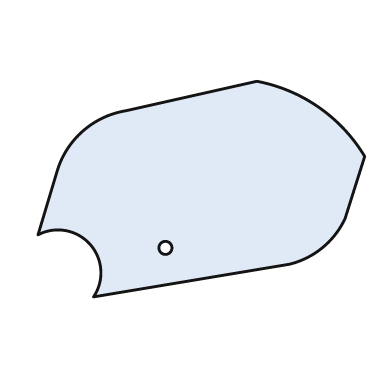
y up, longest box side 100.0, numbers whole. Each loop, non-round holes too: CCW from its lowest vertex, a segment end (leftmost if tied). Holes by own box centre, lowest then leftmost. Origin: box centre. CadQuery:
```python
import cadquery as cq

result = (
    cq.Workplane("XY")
    .moveTo(-33.0, -33.0)
    .lineTo(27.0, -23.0)
    .threePointArc((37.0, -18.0), (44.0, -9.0))
    .lineTo(50.0, 10.0)
    .threePointArc((36.0, 25.0), (17.0, 33.0))
    .lineTo(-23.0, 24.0)
    .threePointArc((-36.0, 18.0), (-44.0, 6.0))
    .lineTo(-50.0, -14.0)
    .threePointArc((-34.0, -17.0), (-33.0, -33.0))
    .close()
    .moveTo(-11.0, -18.0)
    .circle(2.0)
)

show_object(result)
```